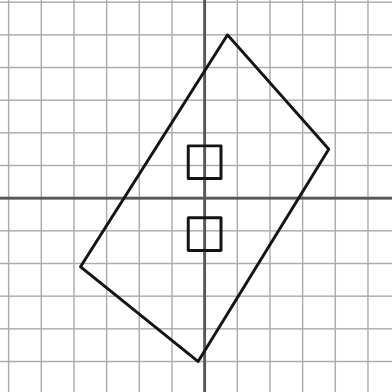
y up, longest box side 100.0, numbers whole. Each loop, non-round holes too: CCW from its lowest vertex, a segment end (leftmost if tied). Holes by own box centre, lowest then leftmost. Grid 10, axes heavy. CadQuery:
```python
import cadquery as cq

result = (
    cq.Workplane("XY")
    .moveTo(-2.0, -50.0)
    .lineTo(38.0, 15.0)
    .lineTo(7.0, 50.0)
    .lineTo(-38.0, -21.0)
    .close()
    .moveTo(-5.0, -16.0)
    .lineTo(5.0, -16.0)
    .lineTo(5.0, -6.0)
    .lineTo(-5.0, -6.0)
    .close()
    .moveTo(-5.0, 6.0)
    .lineTo(5.0, 6.0)
    .lineTo(5.0, 16.0)
    .lineTo(-5.0, 16.0)
    .close()
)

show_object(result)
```